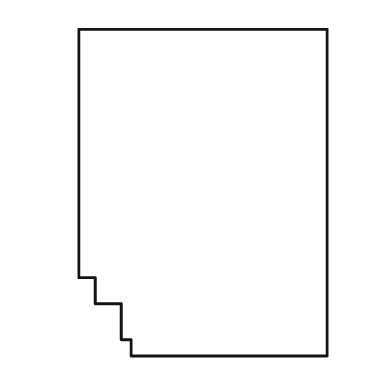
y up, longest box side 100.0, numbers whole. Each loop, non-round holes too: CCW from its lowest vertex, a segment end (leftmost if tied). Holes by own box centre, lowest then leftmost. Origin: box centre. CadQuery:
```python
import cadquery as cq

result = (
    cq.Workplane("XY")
    .moveTo(-22.0, -50.0)
    .lineTo(38.0, -50.0)
    .lineTo(38.0, 50.0)
    .lineTo(-38.0, 50.0)
    .lineTo(-38.0, -26.0)
    .lineTo(-33.0, -26.0)
    .lineTo(-33.0, -34.0)
    .lineTo(-25.0, -34.0)
    .lineTo(-25.0, -45.0)
    .lineTo(-22.0, -45.0)
    .close()
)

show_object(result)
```